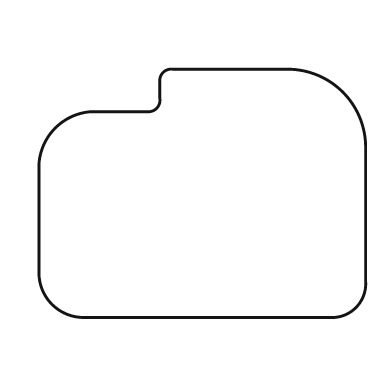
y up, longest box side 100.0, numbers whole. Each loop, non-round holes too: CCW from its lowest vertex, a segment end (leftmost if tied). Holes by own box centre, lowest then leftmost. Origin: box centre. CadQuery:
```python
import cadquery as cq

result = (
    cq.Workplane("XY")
    .moveTo(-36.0, -38.0)
    .lineTo(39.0, -38.0)
    .threePointArc((47.0, -35.0), (50.0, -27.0))
    .lineTo(50.0, 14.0)
    .threePointArc((43.0, 31.0), (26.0, 38.0))
    .lineTo(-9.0, 38.0)
    .threePointArc((-12.0, 37.0), (-13.0, 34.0))
    .lineTo(-13.0, 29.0)
    .threePointArc((-14.0, 26.0), (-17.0, 25.0))
    .lineTo(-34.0, 25.0)
    .threePointArc((-45.0, 20.0), (-50.0, 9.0))
    .lineTo(-50.0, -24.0)
    .threePointArc((-46.0, -34.0), (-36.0, -38.0))
    .close()
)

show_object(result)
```